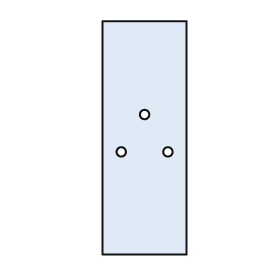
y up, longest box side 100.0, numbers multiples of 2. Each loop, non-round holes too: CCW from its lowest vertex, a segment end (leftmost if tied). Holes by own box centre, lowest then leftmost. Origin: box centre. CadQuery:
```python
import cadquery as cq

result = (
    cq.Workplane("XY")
    .moveTo(-18.0, -50.0)
    .lineTo(18.0, -50.0)
    .lineTo(18.0, 50.0)
    .lineTo(-18.0, 50.0)
    .close()
    .moveTo(-10.0, -6.0)
    .circle(2.0)
    .moveTo(10.0, -6.0)
    .circle(2.0)
    .moveTo(0.0, 10.0)
    .circle(2.0)
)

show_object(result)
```